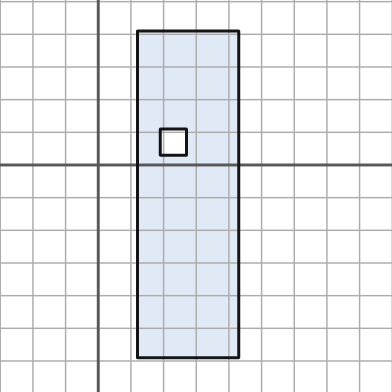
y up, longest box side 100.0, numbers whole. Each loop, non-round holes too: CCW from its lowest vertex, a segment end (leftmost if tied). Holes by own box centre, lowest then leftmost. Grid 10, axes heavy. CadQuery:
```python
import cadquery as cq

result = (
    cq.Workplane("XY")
    .moveTo(12.0, -59.0)
    .lineTo(43.0, -59.0)
    .lineTo(43.0, 41.0)
    .lineTo(12.0, 41.0)
    .close()
    .moveTo(19.0, 3.0)
    .lineTo(27.0, 3.0)
    .lineTo(27.0, 11.0)
    .lineTo(19.0, 11.0)
    .close()
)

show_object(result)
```